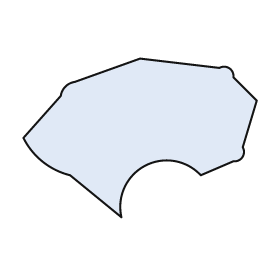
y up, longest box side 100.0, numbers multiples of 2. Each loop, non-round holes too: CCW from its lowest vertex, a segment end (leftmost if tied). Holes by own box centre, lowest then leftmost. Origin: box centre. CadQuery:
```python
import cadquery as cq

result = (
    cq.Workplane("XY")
    .moveTo(-8.0, -34.0)
    .threePointArc((2.0, -12.0), (26.0, -16.0))
    .lineTo(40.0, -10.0)
    .threePointArc((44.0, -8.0), (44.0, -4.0))
    .lineTo(50.0, 16.0)
    .lineTo(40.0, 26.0)
    .threePointArc((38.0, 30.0), (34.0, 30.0))
    .lineTo(0.0, 34.0)
    .lineTo(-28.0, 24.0)
    .threePointArc((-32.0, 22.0), (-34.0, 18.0))
    .lineTo(-50.0, 0.0)
    .threePointArc((-42.0, -10.0), (-30.0, -16.0))
    .close()
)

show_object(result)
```